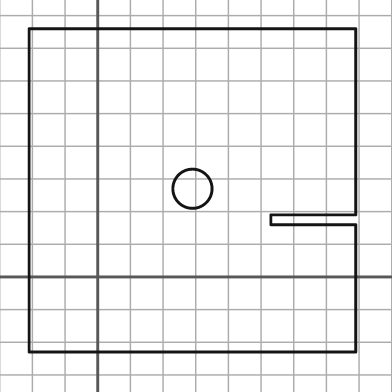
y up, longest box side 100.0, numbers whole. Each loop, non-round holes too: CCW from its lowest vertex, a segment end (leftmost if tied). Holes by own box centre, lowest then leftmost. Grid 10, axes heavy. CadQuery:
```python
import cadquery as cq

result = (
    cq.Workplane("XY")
    .moveTo(-21.0, -23.0)
    .lineTo(79.0, -23.0)
    .lineTo(79.0, 16.0)
    .lineTo(53.0, 16.0)
    .lineTo(53.0, 19.0)
    .lineTo(79.0, 19.0)
    .lineTo(79.0, 76.0)
    .lineTo(-21.0, 76.0)
    .close()
    .moveTo(29.0, 27.0)
    .circle(6.0)
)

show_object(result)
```